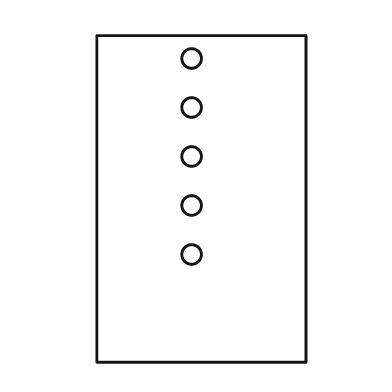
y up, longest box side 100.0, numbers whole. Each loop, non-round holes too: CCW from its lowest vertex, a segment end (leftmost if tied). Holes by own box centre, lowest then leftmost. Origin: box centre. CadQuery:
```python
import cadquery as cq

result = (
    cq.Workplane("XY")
    .moveTo(-32.0, -50.0)
    .lineTo(32.0, -50.0)
    .lineTo(32.0, 50.0)
    .lineTo(-32.0, 50.0)
    .close()
    .moveTo(-3.0, -17.0)
    .circle(3.0)
    .moveTo(-3.0, -2.0)
    .circle(3.0)
    .moveTo(-3.0, 13.0)
    .circle(3.0)
    .moveTo(-3.0, 28.0)
    .circle(3.0)
    .moveTo(-3.0, 43.0)
    .circle(3.0)
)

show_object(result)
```